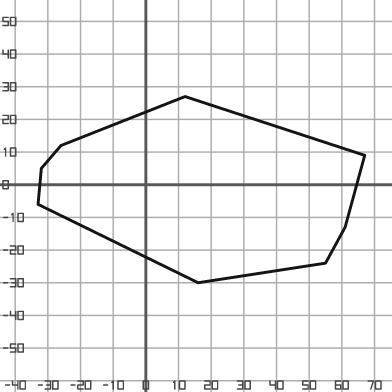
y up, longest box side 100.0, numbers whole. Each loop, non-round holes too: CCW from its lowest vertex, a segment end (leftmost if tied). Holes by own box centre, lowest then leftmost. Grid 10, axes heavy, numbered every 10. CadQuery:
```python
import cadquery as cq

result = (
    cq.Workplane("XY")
    .moveTo(16.0, -30.0)
    .lineTo(55.0, -24.0)
    .lineTo(61.0, -13.0)
    .lineTo(67.0, 9.0)
    .lineTo(12.0, 27.0)
    .lineTo(-26.0, 12.0)
    .lineTo(-32.0, 5.0)
    .lineTo(-33.0, -6.0)
    .close()
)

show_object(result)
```